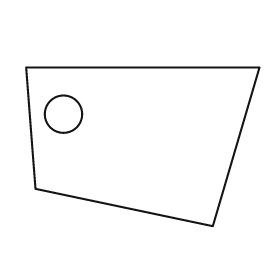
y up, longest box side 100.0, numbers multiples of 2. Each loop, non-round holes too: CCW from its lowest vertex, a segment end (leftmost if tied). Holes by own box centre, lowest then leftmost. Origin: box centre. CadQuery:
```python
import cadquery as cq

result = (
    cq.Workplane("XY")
    .moveTo(30.0, -34.0)
    .lineTo(50.0, 34.0)
    .lineTo(-50.0, 34.0)
    .lineTo(-46.0, -18.0)
    .close()
    .moveTo(-34.0, 14.0)
    .circle(8.0)
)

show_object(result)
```